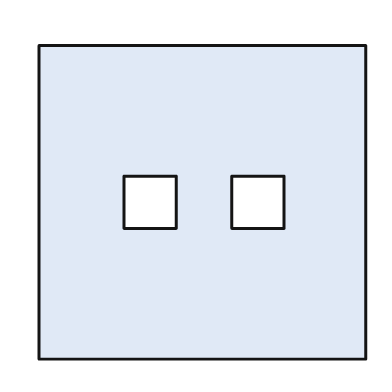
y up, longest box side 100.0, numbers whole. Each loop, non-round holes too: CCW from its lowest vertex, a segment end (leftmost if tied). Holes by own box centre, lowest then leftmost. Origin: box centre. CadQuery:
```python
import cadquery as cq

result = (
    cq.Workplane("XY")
    .moveTo(-50.0, -48.0)
    .lineTo(50.0, -48.0)
    .lineTo(50.0, 48.0)
    .lineTo(-50.0, 48.0)
    .close()
    .moveTo(-24.0, -8.0)
    .lineTo(-8.0, -8.0)
    .lineTo(-8.0, 8.0)
    .lineTo(-24.0, 8.0)
    .close()
    .moveTo(9.0, -8.0)
    .lineTo(25.0, -8.0)
    .lineTo(25.0, 8.0)
    .lineTo(9.0, 8.0)
    .close()
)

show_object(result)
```